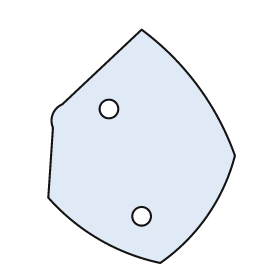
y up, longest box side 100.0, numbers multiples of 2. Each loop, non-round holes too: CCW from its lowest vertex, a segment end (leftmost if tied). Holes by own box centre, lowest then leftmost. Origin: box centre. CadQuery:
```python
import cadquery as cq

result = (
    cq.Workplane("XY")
    .moveTo(8.0, -50.0)
    .threePointArc((28.0, -30.0), (40.0, -4.0))
    .threePointArc((24.0, 26.0), (0.0, 50.0))
    .lineTo(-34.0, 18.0)
    .threePointArc((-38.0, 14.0), (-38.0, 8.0))
    .lineTo(-40.0, -22.0)
    .threePointArc((-18.0, -40.0), (8.0, -50.0))
    .close()
    .moveTo(0.0, -30.0)
    .circle(4.0)
    .moveTo(-14.0, 16.0)
    .circle(4.0)
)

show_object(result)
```